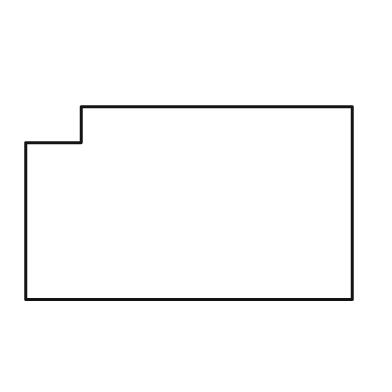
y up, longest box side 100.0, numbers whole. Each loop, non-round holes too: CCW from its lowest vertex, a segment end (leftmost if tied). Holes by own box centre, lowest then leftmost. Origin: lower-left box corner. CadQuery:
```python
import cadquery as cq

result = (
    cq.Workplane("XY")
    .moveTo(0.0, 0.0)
    .lineTo(100.0, 0.0)
    .lineTo(100.0, 59.0)
    .lineTo(17.0, 59.0)
    .lineTo(17.0, 48.0)
    .lineTo(0.0, 48.0)
    .close()
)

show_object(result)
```